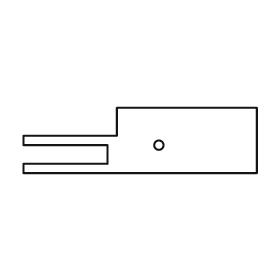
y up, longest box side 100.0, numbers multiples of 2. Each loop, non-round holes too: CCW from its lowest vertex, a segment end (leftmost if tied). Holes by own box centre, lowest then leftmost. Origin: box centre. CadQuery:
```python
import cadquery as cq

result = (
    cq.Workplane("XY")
    .moveTo(-50.0, -14.0)
    .lineTo(50.0, -14.0)
    .lineTo(50.0, 14.0)
    .lineTo(-10.0, 14.0)
    .lineTo(-10.0, 2.0)
    .lineTo(-50.0, 2.0)
    .lineTo(-50.0, -2.0)
    .lineTo(-14.0, -2.0)
    .lineTo(-14.0, -10.0)
    .lineTo(-50.0, -10.0)
    .close()
    .moveTo(8.0, -2.0)
    .circle(2.0)
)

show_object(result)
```